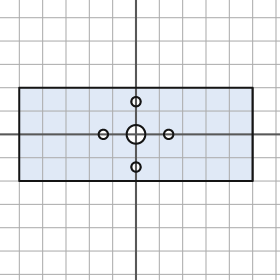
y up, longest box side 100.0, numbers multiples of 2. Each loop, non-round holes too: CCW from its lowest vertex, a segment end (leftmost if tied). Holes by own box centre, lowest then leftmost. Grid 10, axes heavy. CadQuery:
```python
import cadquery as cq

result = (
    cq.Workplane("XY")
    .moveTo(-50.0, -20.0)
    .lineTo(50.0, -20.0)
    .lineTo(50.0, 20.0)
    .lineTo(-50.0, 20.0)
    .close()
    .moveTo(0.0, -14.0)
    .circle(2.0)
    .moveTo(-14.0, 0.0)
    .circle(2.0)
    .moveTo(0.0, 0.0)
    .circle(4.0)
    .moveTo(14.0, 0.0)
    .circle(2.0)
    .moveTo(0.0, 14.0)
    .circle(2.0)
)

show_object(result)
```